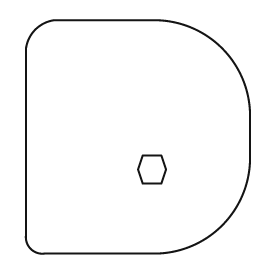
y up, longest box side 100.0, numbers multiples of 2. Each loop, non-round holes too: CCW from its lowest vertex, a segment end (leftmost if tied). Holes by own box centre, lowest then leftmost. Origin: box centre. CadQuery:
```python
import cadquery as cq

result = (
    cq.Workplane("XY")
    .moveTo(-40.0, -50.0)
    .lineTo(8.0, -50.0)
    .threePointArc((36.0, -38.0), (48.0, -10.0))
    .lineTo(48.0, 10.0)
    .threePointArc((36.0, 38.0), (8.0, 50.0))
    .lineTo(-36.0, 50.0)
    .threePointArc((-44.0, 46.0), (-48.0, 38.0))
    .lineTo(-48.0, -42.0)
    .threePointArc((-46.0, -48.0), (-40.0, -50.0))
    .close()
    .moveTo(2.0, -20.0)
    .lineTo(10.0, -20.0)
    .lineTo(12.0, -14.0)
    .lineTo(10.0, -8.0)
    .lineTo(2.0, -8.0)
    .lineTo(0.0, -14.0)
    .close()
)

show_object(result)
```